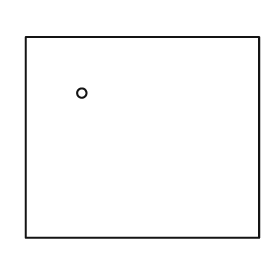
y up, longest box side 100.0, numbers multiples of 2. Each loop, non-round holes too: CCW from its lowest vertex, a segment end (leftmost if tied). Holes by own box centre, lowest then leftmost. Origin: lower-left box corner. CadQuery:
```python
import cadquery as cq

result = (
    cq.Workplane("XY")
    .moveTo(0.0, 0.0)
    .lineTo(100.0, 0.0)
    .lineTo(100.0, 86.0)
    .lineTo(0.0, 86.0)
    .close()
    .moveTo(24.0, 62.0)
    .circle(2.0)
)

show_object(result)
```